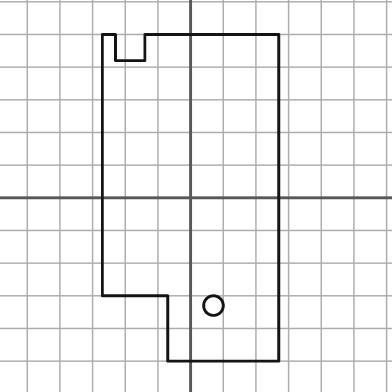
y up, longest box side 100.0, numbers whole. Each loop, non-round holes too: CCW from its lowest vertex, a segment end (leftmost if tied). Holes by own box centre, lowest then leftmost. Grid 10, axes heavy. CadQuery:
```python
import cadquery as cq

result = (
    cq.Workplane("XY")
    .moveTo(-7.0, -50.0)
    .lineTo(27.0, -50.0)
    .lineTo(27.0, 50.0)
    .lineTo(-14.0, 50.0)
    .lineTo(-14.0, 42.0)
    .lineTo(-23.0, 42.0)
    .lineTo(-23.0, 50.0)
    .lineTo(-27.0, 50.0)
    .lineTo(-27.0, -30.0)
    .lineTo(-7.0, -30.0)
    .close()
    .moveTo(7.0, -33.0)
    .circle(3.0)
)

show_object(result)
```